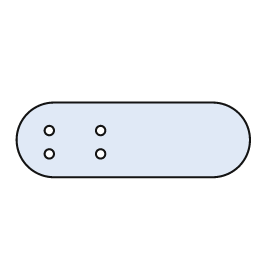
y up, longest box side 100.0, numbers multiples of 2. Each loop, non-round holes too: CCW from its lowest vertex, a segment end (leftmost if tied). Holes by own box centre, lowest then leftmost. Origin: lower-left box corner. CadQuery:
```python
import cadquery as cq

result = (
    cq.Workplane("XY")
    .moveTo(16.0, 0.0)
    .lineTo(84.0, 0.0)
    .threePointArc((100.0, 16.0), (84.0, 32.0))
    .lineTo(16.0, 32.0)
    .threePointArc((0.0, 16.0), (16.0, 0.0))
    .close()
    .moveTo(14.0, 10.0)
    .circle(2.0)
    .moveTo(36.0, 10.0)
    .circle(2.0)
    .moveTo(14.0, 20.0)
    .circle(2.0)
    .moveTo(36.0, 20.0)
    .circle(2.0)
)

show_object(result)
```